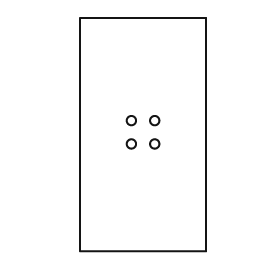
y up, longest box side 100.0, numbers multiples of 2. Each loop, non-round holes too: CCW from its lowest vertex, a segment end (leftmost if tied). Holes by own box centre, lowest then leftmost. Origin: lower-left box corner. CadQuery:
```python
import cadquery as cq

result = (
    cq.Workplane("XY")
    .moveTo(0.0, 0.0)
    .lineTo(54.0, 0.0)
    .lineTo(54.0, 100.0)
    .lineTo(0.0, 100.0)
    .close()
    .moveTo(22.0, 46.0)
    .circle(2.0)
    .moveTo(32.0, 46.0)
    .circle(2.0)
    .moveTo(22.0, 56.0)
    .circle(2.0)
    .moveTo(32.0, 56.0)
    .circle(2.0)
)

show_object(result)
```